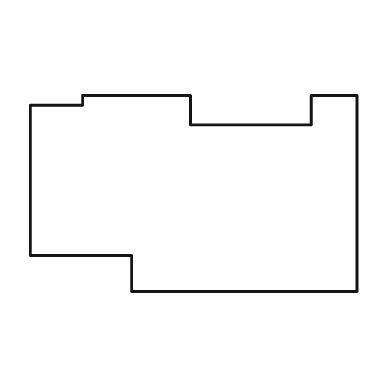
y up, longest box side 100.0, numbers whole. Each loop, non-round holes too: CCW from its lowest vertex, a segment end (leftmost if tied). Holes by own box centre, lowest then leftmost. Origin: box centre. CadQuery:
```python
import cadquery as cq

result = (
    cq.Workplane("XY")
    .moveTo(-19.0, -30.0)
    .lineTo(50.0, -30.0)
    .lineTo(50.0, 30.0)
    .lineTo(36.0, 30.0)
    .lineTo(36.0, 21.0)
    .lineTo(-1.0, 21.0)
    .lineTo(-1.0, 30.0)
    .lineTo(-34.0, 30.0)
    .lineTo(-34.0, 27.0)
    .lineTo(-50.0, 27.0)
    .lineTo(-50.0, -19.0)
    .lineTo(-19.0, -19.0)
    .close()
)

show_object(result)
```